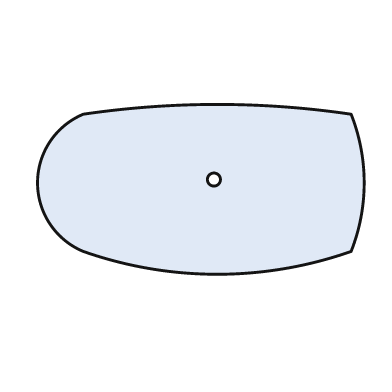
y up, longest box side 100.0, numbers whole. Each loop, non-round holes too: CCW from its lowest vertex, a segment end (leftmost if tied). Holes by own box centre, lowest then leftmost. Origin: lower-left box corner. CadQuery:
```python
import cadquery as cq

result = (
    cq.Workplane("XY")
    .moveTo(14.0, 7.0)
    .threePointArc((55.0, 0.0), (96.0, 7.0))
    .threePointArc((100.0, 28.0), (96.0, 49.0))
    .threePointArc((55.0, 52.0), (14.0, 49.0))
    .threePointArc((0.0, 28.0), (14.0, 7.0))
    .close()
    .moveTo(54.0, 29.0)
    .circle(2.0)
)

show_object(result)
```